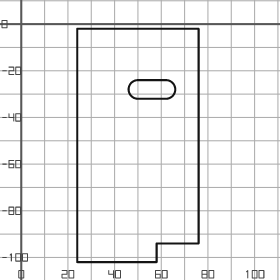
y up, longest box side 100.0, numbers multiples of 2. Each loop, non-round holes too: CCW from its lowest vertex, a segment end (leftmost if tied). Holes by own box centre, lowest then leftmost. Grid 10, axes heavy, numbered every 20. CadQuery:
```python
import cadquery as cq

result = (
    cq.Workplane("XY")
    .moveTo(24.0, -102.0)
    .lineTo(58.0, -102.0)
    .lineTo(58.0, -94.0)
    .lineTo(76.0, -94.0)
    .lineTo(76.0, -2.0)
    .lineTo(24.0, -2.0)
    .close()
    .moveTo(50.0, -32.0)
    .lineTo(62.0, -32.0)
    .threePointArc((66.0, -28.0), (62.0, -24.0))
    .lineTo(50.0, -24.0)
    .threePointArc((46.0, -28.0), (50.0, -32.0))
    .close()
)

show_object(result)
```